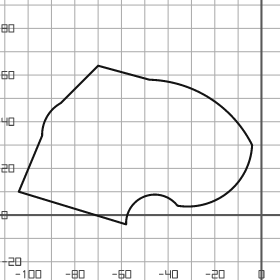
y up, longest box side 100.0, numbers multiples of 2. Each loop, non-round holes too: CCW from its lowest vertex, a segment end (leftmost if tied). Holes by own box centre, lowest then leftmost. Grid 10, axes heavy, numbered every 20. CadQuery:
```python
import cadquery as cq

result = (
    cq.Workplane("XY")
    .moveTo(-58.0, -4.0)
    .threePointArc((-50.0, 8.0), (-36.0, 4.0))
    .threePointArc((-14.0, 10.0), (-4.0, 30.0))
    .threePointArc((-22.0, 50.0), (-48.0, 58.0))
    .lineTo(-70.0, 64.0)
    .lineTo(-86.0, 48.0)
    .threePointArc((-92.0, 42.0), (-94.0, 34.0))
    .lineTo(-104.0, 10.0)
    .close()
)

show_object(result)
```